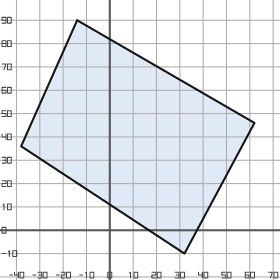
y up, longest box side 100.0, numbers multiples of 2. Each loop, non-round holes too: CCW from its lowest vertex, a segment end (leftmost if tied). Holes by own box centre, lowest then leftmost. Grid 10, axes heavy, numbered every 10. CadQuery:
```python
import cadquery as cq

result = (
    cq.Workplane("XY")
    .moveTo(32.0, -10.0)
    .lineTo(62.0, 46.0)
    .lineTo(-14.0, 90.0)
    .lineTo(-38.0, 36.0)
    .close()
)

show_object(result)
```